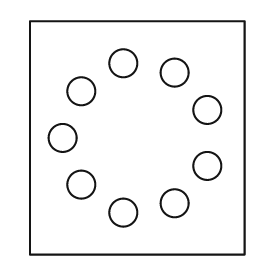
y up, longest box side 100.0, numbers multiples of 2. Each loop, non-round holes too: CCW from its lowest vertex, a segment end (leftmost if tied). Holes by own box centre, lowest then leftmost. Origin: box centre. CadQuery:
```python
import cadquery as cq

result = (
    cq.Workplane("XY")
    .moveTo(-46.0, -50.0)
    .lineTo(46.0, -50.0)
    .lineTo(46.0, 50.0)
    .lineTo(-46.0, 50.0)
    .close()
    .moveTo(-6.0, -32.0)
    .circle(6.0)
    .moveTo(16.0, -28.0)
    .circle(6.0)
    .moveTo(-24.0, -20.0)
    .circle(6.0)
    .moveTo(30.0, -12.0)
    .circle(6.0)
    .moveTo(-32.0, 0.0)
    .circle(6.0)
    .moveTo(30.0, 12.0)
    .circle(6.0)
    .moveTo(-24.0, 20.0)
    .circle(6.0)
    .moveTo(16.0, 28.0)
    .circle(6.0)
    .moveTo(-6.0, 32.0)
    .circle(6.0)
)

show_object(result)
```